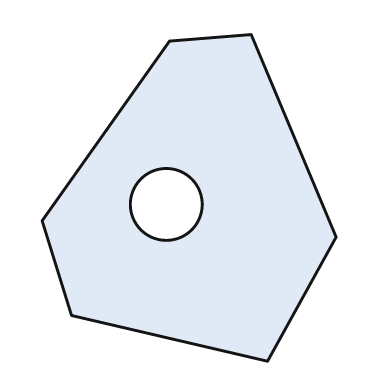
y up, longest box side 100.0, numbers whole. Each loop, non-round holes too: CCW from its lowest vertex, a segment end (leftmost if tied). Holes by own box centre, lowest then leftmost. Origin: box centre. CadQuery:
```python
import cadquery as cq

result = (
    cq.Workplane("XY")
    .moveTo(24.0, -50.0)
    .lineTo(45.0, -12.0)
    .lineTo(19.0, 50.0)
    .lineTo(-6.0, 48.0)
    .lineTo(-45.0, -7.0)
    .lineTo(-36.0, -36.0)
    .close()
    .moveTo(-7.0, -2.0)
    .circle(11.0)
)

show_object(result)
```